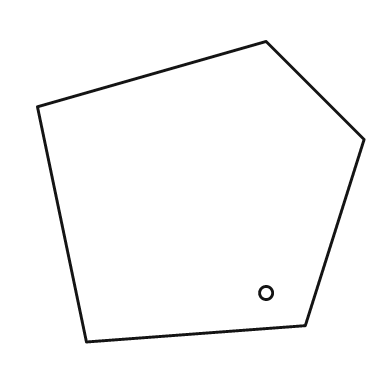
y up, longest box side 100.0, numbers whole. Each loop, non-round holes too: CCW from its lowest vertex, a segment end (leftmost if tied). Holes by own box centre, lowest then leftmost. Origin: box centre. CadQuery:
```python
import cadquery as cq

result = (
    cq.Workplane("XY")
    .moveTo(-35.0, -46.0)
    .lineTo(32.0, -41.0)
    .lineTo(50.0, 16.0)
    .lineTo(20.0, 46.0)
    .lineTo(-50.0, 26.0)
    .close()
    .moveTo(20.0, -31.0)
    .circle(2.0)
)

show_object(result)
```